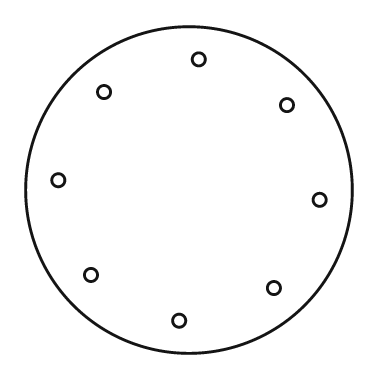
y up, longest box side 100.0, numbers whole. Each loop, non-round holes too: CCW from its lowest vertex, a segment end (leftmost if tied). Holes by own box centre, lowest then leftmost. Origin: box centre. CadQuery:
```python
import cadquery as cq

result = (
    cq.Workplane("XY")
    .moveTo(0.0, 0.0)
    .circle(50.0)
    .moveTo(-3.0, -40.0)
    .circle(2.0)
    .moveTo(26.0, -30.0)
    .circle(2.0)
    .moveTo(-30.0, -26.0)
    .circle(2.0)
    .moveTo(40.0, -3.0)
    .circle(2.0)
    .moveTo(-40.0, 3.0)
    .circle(2.0)
    .moveTo(30.0, 26.0)
    .circle(2.0)
    .moveTo(-26.0, 30.0)
    .circle(2.0)
    .moveTo(3.0, 40.0)
    .circle(2.0)
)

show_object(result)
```